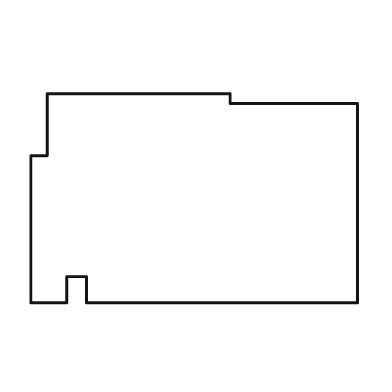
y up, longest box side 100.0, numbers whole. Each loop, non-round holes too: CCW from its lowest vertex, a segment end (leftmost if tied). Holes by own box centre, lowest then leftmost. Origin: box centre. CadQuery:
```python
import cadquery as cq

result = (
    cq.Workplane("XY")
    .moveTo(-50.0, -32.0)
    .lineTo(-39.0, -32.0)
    .lineTo(-39.0, -24.0)
    .lineTo(-33.0, -24.0)
    .lineTo(-33.0, -32.0)
    .lineTo(50.0, -32.0)
    .lineTo(50.0, 29.0)
    .lineTo(11.0, 29.0)
    .lineTo(11.0, 32.0)
    .lineTo(-45.0, 32.0)
    .lineTo(-45.0, 13.0)
    .lineTo(-50.0, 13.0)
    .close()
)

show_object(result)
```